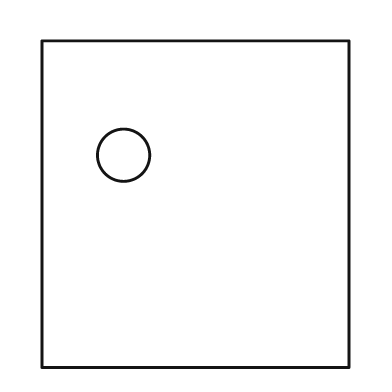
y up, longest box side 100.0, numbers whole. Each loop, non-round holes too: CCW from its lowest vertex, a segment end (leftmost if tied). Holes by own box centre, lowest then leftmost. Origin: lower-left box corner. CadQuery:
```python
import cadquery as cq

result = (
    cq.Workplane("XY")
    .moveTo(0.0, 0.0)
    .lineTo(94.0, 0.0)
    .lineTo(94.0, 100.0)
    .lineTo(0.0, 100.0)
    .close()
    .moveTo(25.0, 65.0)
    .circle(8.0)
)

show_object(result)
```